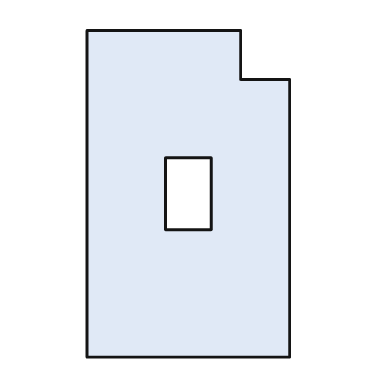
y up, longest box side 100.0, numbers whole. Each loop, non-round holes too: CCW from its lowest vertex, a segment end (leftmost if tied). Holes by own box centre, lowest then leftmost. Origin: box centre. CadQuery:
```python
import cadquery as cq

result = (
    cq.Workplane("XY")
    .moveTo(-31.0, -50.0)
    .lineTo(31.0, -50.0)
    .lineTo(31.0, 35.0)
    .lineTo(16.0, 35.0)
    .lineTo(16.0, 50.0)
    .lineTo(-31.0, 50.0)
    .close()
    .moveTo(-7.0, -11.0)
    .lineTo(7.0, -11.0)
    .lineTo(7.0, 11.0)
    .lineTo(-7.0, 11.0)
    .close()
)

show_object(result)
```